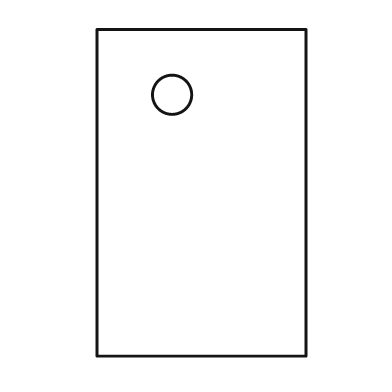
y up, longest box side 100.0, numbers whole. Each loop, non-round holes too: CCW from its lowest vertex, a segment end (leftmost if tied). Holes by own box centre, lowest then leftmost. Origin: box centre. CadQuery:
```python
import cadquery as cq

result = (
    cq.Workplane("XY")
    .moveTo(-32.0, -50.0)
    .lineTo(32.0, -50.0)
    .lineTo(32.0, 50.0)
    .lineTo(-32.0, 50.0)
    .close()
    .moveTo(-9.0, 30.0)
    .circle(6.0)
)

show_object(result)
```